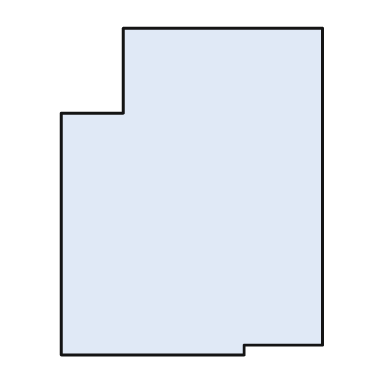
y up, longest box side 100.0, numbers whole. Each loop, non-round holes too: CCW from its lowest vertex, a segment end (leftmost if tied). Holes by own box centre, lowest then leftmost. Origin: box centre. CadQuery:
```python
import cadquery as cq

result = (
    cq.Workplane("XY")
    .moveTo(-40.0, -50.0)
    .lineTo(16.0, -50.0)
    .lineTo(16.0, -47.0)
    .lineTo(40.0, -47.0)
    .lineTo(40.0, 50.0)
    .lineTo(-21.0, 50.0)
    .lineTo(-21.0, 24.0)
    .lineTo(-40.0, 24.0)
    .close()
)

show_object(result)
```